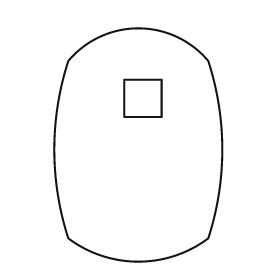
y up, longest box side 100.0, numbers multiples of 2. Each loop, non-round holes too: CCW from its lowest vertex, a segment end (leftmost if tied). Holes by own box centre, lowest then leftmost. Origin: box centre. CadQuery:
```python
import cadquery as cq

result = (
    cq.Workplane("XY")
    .moveTo(-30.0, -40.0)
    .threePointArc((0.0, -50.0), (30.0, -40.0))
    .threePointArc((36.0, -2.0), (30.0, 36.0))
    .threePointArc((0.0, 50.0), (-30.0, 36.0))
    .threePointArc((-36.0, -2.0), (-30.0, -40.0))
    .close()
    .moveTo(-6.0, 12.0)
    .lineTo(10.0, 12.0)
    .lineTo(10.0, 28.0)
    .lineTo(-6.0, 28.0)
    .close()
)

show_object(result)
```